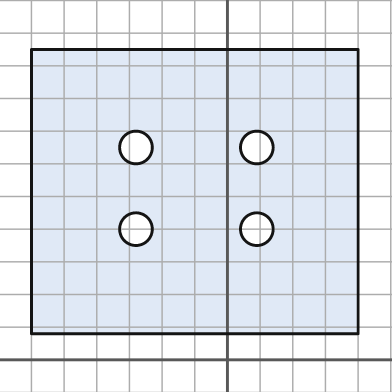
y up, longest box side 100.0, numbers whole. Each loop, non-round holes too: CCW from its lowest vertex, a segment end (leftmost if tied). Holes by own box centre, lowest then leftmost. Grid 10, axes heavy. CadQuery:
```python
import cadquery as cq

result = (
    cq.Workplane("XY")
    .moveTo(-60.0, 8.0)
    .lineTo(40.0, 8.0)
    .lineTo(40.0, 95.0)
    .lineTo(-60.0, 95.0)
    .close()
    .moveTo(-28.0, 40.0)
    .circle(5.0)
    .moveTo(9.0, 40.0)
    .circle(5.0)
    .moveTo(-28.0, 65.0)
    .circle(5.0)
    .moveTo(9.0, 65.0)
    .circle(5.0)
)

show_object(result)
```